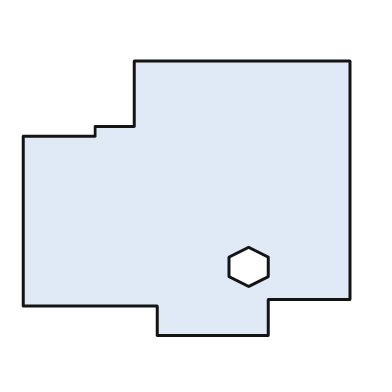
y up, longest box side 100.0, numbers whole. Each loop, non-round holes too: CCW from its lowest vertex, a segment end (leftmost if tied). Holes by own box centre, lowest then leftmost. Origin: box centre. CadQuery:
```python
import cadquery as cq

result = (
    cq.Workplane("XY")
    .moveTo(-9.0, -42.0)
    .lineTo(25.0, -42.0)
    .lineTo(25.0, -31.0)
    .lineTo(50.0, -31.0)
    .lineTo(50.0, 42.0)
    .lineTo(-16.0, 42.0)
    .lineTo(-16.0, 22.0)
    .lineTo(-28.0, 22.0)
    .lineTo(-28.0, 19.0)
    .lineTo(-50.0, 19.0)
    .lineTo(-50.0, -33.0)
    .lineTo(-9.0, -33.0)
    .close()
    .moveTo(19.0, -27.0)
    .lineTo(25.0, -24.0)
    .lineTo(25.0, -18.0)
    .lineTo(19.0, -15.0)
    .lineTo(13.0, -18.0)
    .lineTo(13.0, -24.0)
    .close()
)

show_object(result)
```